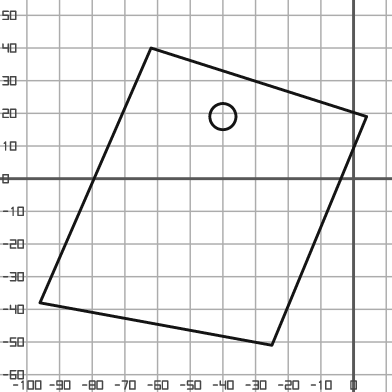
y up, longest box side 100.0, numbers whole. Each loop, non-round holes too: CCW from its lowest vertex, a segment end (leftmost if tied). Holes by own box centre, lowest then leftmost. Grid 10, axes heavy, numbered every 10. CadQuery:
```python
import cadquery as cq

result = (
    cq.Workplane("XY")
    .moveTo(-25.0, -51.0)
    .lineTo(4.0, 19.0)
    .lineTo(-62.0, 40.0)
    .lineTo(-96.0, -38.0)
    .close()
    .moveTo(-40.0, 19.0)
    .circle(4.0)
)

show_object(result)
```